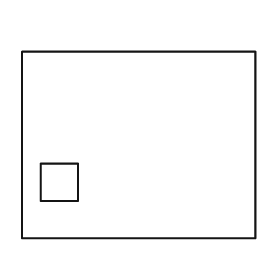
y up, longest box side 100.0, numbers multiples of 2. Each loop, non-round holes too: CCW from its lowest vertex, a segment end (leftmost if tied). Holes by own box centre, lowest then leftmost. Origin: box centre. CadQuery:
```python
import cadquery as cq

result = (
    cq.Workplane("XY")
    .moveTo(-50.0, -40.0)
    .lineTo(50.0, -40.0)
    .lineTo(50.0, 40.0)
    .lineTo(-50.0, 40.0)
    .close()
    .moveTo(-42.0, -24.0)
    .lineTo(-26.0, -24.0)
    .lineTo(-26.0, -8.0)
    .lineTo(-42.0, -8.0)
    .close()
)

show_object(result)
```